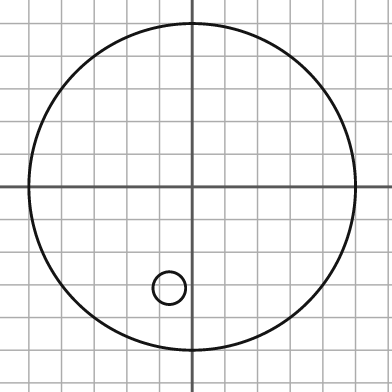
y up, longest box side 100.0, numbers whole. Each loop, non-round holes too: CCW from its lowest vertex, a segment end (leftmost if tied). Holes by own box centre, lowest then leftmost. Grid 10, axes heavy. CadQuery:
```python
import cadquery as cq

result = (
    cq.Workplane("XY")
    .moveTo(0.0, 0.0)
    .circle(50.0)
    .moveTo(-7.0, -31.0)
    .circle(5.0)
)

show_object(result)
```